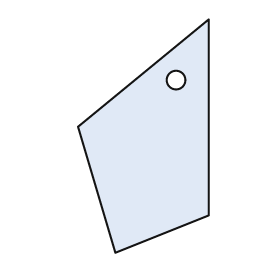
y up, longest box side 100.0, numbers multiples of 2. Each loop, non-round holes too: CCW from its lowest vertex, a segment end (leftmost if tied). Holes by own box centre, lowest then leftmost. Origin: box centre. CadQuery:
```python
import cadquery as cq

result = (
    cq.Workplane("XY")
    .moveTo(-12.0, -50.0)
    .lineTo(28.0, -34.0)
    .lineTo(28.0, 50.0)
    .lineTo(-28.0, 4.0)
    .close()
    .moveTo(14.0, 24.0)
    .circle(4.0)
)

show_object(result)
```